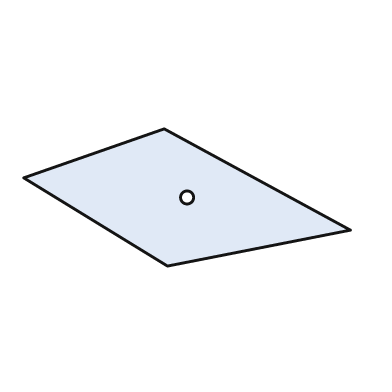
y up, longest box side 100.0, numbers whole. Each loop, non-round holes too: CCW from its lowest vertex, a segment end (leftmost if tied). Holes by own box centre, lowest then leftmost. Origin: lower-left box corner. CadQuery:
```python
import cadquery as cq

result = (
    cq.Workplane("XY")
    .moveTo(44.0, 0.0)
    .lineTo(100.0, 11.0)
    .lineTo(43.0, 42.0)
    .lineTo(0.0, 27.0)
    .close()
    .moveTo(50.0, 21.0)
    .circle(2.0)
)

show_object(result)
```